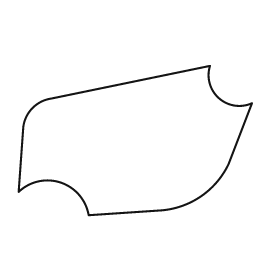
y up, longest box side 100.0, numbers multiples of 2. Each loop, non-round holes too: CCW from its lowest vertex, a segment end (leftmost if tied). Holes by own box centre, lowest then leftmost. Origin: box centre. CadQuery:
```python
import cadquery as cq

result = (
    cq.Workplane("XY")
    .moveTo(-20.0, -32.0)
    .lineTo(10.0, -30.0)
    .threePointArc((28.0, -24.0), (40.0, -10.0))
    .lineTo(50.0, 16.0)
    .threePointArc((36.0, 18.0), (32.0, 32.0))
    .lineTo(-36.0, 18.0)
    .threePointArc((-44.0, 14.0), (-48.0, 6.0))
    .lineTo(-50.0, -22.0)
    .threePointArc((-32.0, -18.0), (-20.0, -32.0))
    .close()
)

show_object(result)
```